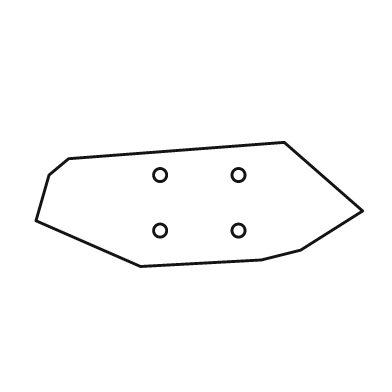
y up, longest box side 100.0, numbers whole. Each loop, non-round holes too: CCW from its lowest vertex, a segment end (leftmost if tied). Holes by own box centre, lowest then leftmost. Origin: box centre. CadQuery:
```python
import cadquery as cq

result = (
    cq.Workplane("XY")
    .moveTo(-18.0, -19.0)
    .lineTo(19.0, -17.0)
    .lineTo(31.0, -14.0)
    .lineTo(50.0, -2.0)
    .lineTo(26.0, 19.0)
    .lineTo(-40.0, 14.0)
    .lineTo(-46.0, 9.0)
    .lineTo(-50.0, -5.0)
    .close()
    .moveTo(-12.0, -8.0)
    .circle(2.0)
    .moveTo(12.0, -8.0)
    .circle(2.0)
    .moveTo(-12.0, 9.0)
    .circle(2.0)
    .moveTo(12.0, 9.0)
    .circle(2.0)
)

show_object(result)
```